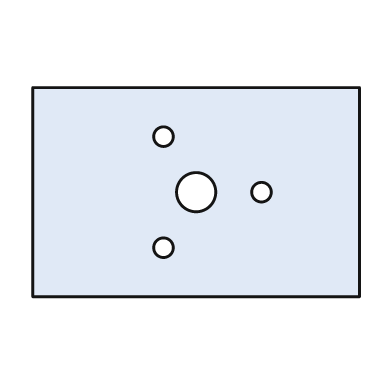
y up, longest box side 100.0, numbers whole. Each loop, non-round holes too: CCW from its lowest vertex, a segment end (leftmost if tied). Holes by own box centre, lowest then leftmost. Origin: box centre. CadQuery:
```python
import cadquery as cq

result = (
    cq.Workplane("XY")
    .moveTo(-50.0, -32.0)
    .lineTo(50.0, -32.0)
    .lineTo(50.0, 32.0)
    .lineTo(-50.0, 32.0)
    .close()
    .moveTo(-10.0, -17.0)
    .circle(3.0)
    .moveTo(0.0, 0.0)
    .circle(6.0)
    .moveTo(20.0, 0.0)
    .circle(3.0)
    .moveTo(-10.0, 17.0)
    .circle(3.0)
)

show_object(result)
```